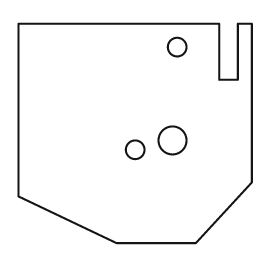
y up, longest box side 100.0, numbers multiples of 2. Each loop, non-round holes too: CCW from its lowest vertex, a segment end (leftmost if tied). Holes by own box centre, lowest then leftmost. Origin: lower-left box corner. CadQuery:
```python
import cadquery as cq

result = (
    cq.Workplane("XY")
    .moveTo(42.0, 0.0)
    .lineTo(76.0, 0.0)
    .lineTo(100.0, 26.0)
    .lineTo(100.0, 94.0)
    .lineTo(94.0, 94.0)
    .lineTo(94.0, 70.0)
    .lineTo(86.0, 70.0)
    .lineTo(86.0, 94.0)
    .lineTo(0.0, 94.0)
    .lineTo(0.0, 20.0)
    .close()
    .moveTo(50.0, 40.0)
    .circle(4.0)
    .moveTo(66.0, 44.0)
    .circle(6.0)
    .moveTo(68.0, 84.0)
    .circle(4.0)
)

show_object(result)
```